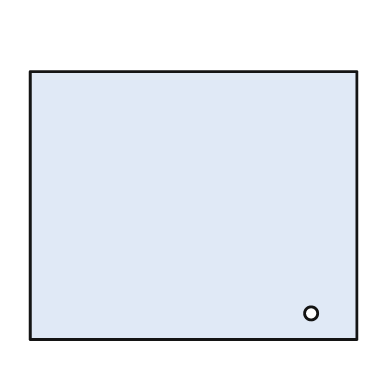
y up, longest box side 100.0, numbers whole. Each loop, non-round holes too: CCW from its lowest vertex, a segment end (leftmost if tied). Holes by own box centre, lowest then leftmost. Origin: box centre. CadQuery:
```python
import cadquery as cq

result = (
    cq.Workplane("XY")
    .moveTo(-50.0, -41.0)
    .lineTo(50.0, -41.0)
    .lineTo(50.0, 41.0)
    .lineTo(-50.0, 41.0)
    .close()
    .moveTo(36.0, -33.0)
    .circle(2.0)
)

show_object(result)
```